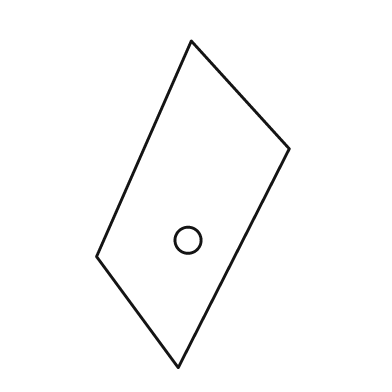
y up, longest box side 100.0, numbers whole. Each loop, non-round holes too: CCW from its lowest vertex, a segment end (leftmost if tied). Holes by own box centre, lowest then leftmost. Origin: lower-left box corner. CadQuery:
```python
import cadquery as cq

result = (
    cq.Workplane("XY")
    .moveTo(25.0, 0.0)
    .lineTo(59.0, 67.0)
    .lineTo(29.0, 100.0)
    .lineTo(0.0, 34.0)
    .close()
    .moveTo(28.0, 39.0)
    .circle(4.0)
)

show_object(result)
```